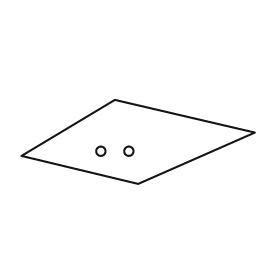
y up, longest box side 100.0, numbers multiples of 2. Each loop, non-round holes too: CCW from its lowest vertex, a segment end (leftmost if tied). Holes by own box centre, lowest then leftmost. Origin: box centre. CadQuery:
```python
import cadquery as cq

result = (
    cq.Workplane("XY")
    .moveTo(0.0, -18.0)
    .lineTo(50.0, 4.0)
    .lineTo(-10.0, 18.0)
    .lineTo(-50.0, -6.0)
    .close()
    .moveTo(-16.0, -4.0)
    .circle(2.0)
    .moveTo(-4.0, -4.0)
    .circle(2.0)
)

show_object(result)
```